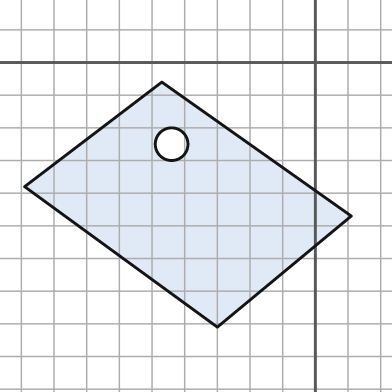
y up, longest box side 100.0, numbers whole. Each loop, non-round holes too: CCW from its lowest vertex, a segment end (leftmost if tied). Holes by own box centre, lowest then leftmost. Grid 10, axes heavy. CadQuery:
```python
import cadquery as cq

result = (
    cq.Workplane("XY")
    .moveTo(-30.0, -81.0)
    .lineTo(11.0, -47.0)
    .lineTo(-47.0, -6.0)
    .lineTo(-89.0, -38.0)
    .close()
    .moveTo(-44.0, -25.0)
    .circle(5.0)
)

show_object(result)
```